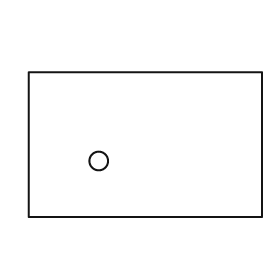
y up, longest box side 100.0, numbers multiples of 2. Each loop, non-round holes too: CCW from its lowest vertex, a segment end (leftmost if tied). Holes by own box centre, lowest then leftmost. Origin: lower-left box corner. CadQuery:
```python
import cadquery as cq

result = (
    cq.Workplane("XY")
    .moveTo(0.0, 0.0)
    .lineTo(100.0, 0.0)
    .lineTo(100.0, 62.0)
    .lineTo(0.0, 62.0)
    .close()
    .moveTo(30.0, 24.0)
    .circle(4.0)
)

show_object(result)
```